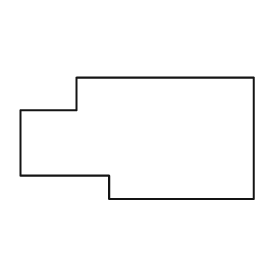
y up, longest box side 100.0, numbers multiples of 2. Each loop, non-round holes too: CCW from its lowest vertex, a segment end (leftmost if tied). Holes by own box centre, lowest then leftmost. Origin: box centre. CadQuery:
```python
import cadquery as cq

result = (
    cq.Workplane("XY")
    .moveTo(-12.0, -26.0)
    .lineTo(50.0, -26.0)
    .lineTo(50.0, 26.0)
    .lineTo(-26.0, 26.0)
    .lineTo(-26.0, 12.0)
    .lineTo(-50.0, 12.0)
    .lineTo(-50.0, -16.0)
    .lineTo(-12.0, -16.0)
    .close()
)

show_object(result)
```